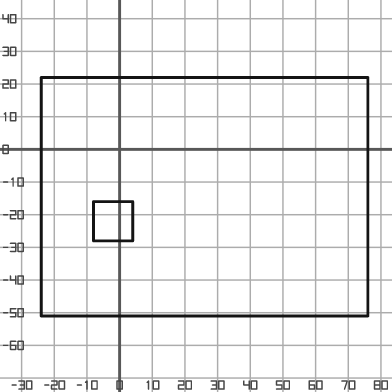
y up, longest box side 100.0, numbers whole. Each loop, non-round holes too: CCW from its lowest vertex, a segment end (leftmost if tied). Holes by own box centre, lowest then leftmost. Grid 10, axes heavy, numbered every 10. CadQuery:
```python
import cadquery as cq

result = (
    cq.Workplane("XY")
    .moveTo(-24.0, -51.0)
    .lineTo(76.0, -51.0)
    .lineTo(76.0, 22.0)
    .lineTo(-24.0, 22.0)
    .close()
    .moveTo(-8.0, -28.0)
    .lineTo(4.0, -28.0)
    .lineTo(4.0, -16.0)
    .lineTo(-8.0, -16.0)
    .close()
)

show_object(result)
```